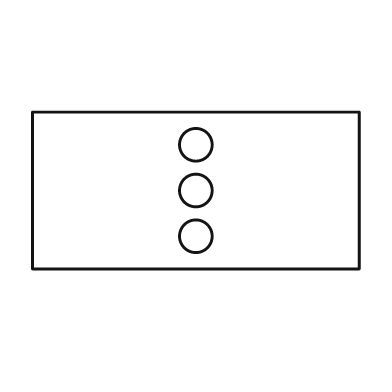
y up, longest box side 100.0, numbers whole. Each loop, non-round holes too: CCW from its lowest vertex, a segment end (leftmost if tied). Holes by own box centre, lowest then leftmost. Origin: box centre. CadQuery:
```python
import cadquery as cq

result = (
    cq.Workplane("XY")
    .moveTo(-50.0, -24.0)
    .lineTo(50.0, -24.0)
    .lineTo(50.0, 24.0)
    .lineTo(-50.0, 24.0)
    .close()
    .moveTo(0.0, -14.0)
    .circle(5.0)
    .moveTo(0.0, 0.0)
    .circle(5.0)
    .moveTo(0.0, 14.0)
    .circle(5.0)
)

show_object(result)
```